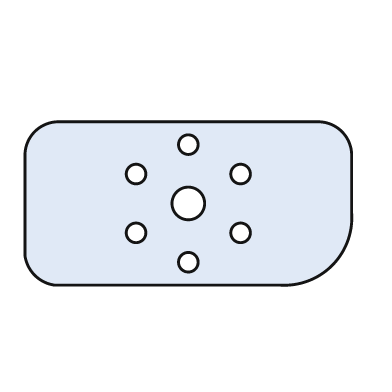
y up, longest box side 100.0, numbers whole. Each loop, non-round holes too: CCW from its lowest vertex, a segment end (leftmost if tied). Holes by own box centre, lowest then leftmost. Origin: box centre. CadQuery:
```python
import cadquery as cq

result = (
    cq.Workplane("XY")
    .moveTo(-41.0, -25.0)
    .lineTo(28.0, -25.0)
    .threePointArc((44.0, -19.0), (50.0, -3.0))
    .lineTo(50.0, 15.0)
    .threePointArc((47.0, 22.0), (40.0, 25.0))
    .lineTo(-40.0, 25.0)
    .threePointArc((-47.0, 22.0), (-50.0, 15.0))
    .lineTo(-50.0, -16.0)
    .threePointArc((-47.0, -22.0), (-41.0, -25.0))
    .close()
    .moveTo(0.0, -18.0)
    .circle(3.0)
    .moveTo(-16.0, -9.0)
    .circle(3.0)
    .moveTo(16.0, -9.0)
    .circle(3.0)
    .moveTo(0.0, 0.0)
    .circle(5.0)
    .moveTo(-16.0, 9.0)
    .circle(3.0)
    .moveTo(16.0, 9.0)
    .circle(3.0)
    .moveTo(0.0, 18.0)
    .circle(3.0)
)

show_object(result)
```